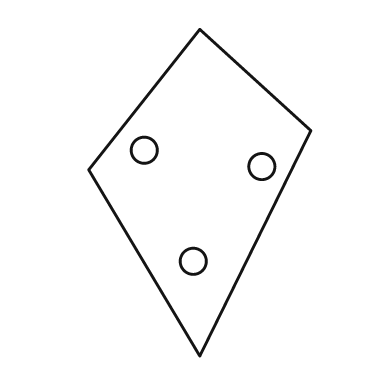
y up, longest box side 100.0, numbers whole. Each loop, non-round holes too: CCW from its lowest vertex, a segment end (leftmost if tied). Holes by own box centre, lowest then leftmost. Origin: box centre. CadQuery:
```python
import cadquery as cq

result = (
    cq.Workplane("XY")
    .moveTo(0.0, -50.0)
    .lineTo(34.0, 19.0)
    .lineTo(0.0, 50.0)
    .lineTo(-34.0, 7.0)
    .close()
    .moveTo(-2.0, -21.0)
    .circle(4.0)
    .moveTo(19.0, 8.0)
    .circle(4.0)
    .moveTo(-17.0, 13.0)
    .circle(4.0)
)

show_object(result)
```